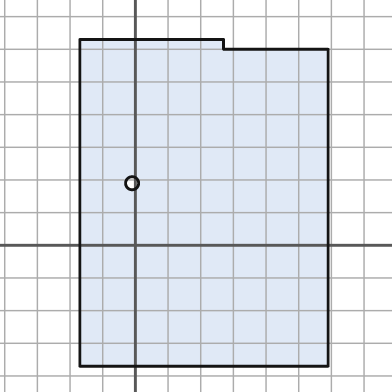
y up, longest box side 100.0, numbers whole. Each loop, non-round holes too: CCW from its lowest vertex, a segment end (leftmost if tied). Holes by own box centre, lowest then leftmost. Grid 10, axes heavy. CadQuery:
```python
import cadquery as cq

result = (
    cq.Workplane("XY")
    .moveTo(-17.0, -37.0)
    .lineTo(59.0, -37.0)
    .lineTo(59.0, 60.0)
    .lineTo(27.0, 60.0)
    .lineTo(27.0, 63.0)
    .lineTo(-17.0, 63.0)
    .close()
    .moveTo(-1.0, 19.0)
    .circle(2.0)
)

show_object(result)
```